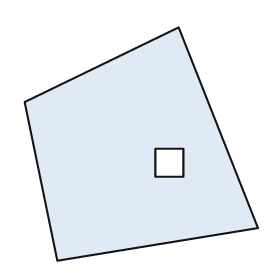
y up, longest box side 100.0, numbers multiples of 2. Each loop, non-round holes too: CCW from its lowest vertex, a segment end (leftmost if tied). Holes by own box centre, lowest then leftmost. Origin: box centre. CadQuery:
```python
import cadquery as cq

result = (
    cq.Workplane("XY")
    .moveTo(-36.0, -50.0)
    .lineTo(50.0, -36.0)
    .lineTo(16.0, 50.0)
    .lineTo(-50.0, 18.0)
    .close()
    .moveTo(6.0, -14.0)
    .lineTo(18.0, -14.0)
    .lineTo(18.0, -2.0)
    .lineTo(6.0, -2.0)
    .close()
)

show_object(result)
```